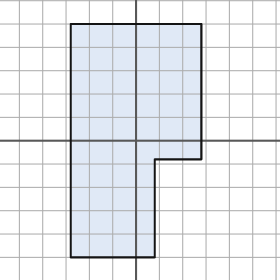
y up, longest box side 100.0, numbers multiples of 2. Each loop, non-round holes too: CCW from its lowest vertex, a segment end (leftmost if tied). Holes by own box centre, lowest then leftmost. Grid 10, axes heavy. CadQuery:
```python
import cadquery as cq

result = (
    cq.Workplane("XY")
    .moveTo(-28.0, -50.0)
    .lineTo(8.0, -50.0)
    .lineTo(8.0, -8.0)
    .lineTo(28.0, -8.0)
    .lineTo(28.0, 50.0)
    .lineTo(-28.0, 50.0)
    .close()
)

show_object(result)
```